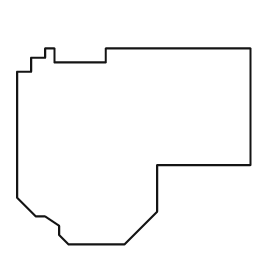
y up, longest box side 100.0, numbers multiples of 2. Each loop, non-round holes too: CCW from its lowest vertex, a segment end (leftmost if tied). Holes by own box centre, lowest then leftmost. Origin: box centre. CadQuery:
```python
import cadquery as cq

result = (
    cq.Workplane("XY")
    .moveTo(-28.0, -42.0)
    .lineTo(-4.0, -42.0)
    .lineTo(10.0, -28.0)
    .lineTo(10.0, -8.0)
    .lineTo(50.0, -8.0)
    .lineTo(50.0, 42.0)
    .lineTo(-12.0, 42.0)
    .lineTo(-12.0, 36.0)
    .lineTo(-34.0, 36.0)
    .lineTo(-34.0, 42.0)
    .lineTo(-38.0, 42.0)
    .lineTo(-38.0, 38.0)
    .lineTo(-44.0, 38.0)
    .lineTo(-44.0, 32.0)
    .lineTo(-50.0, 32.0)
    .lineTo(-50.0, -22.0)
    .lineTo(-42.0, -30.0)
    .lineTo(-38.0, -30.0)
    .lineTo(-32.0, -34.0)
    .lineTo(-32.0, -38.0)
    .close()
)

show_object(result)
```